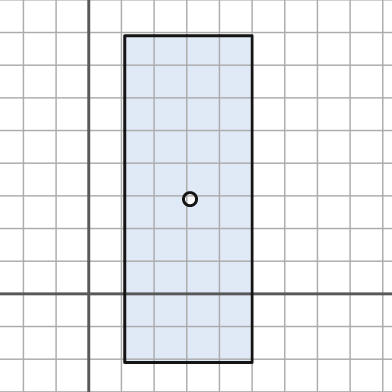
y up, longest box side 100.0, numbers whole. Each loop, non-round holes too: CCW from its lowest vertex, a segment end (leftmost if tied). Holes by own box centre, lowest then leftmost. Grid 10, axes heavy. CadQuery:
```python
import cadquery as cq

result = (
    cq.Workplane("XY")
    .moveTo(11.0, -21.0)
    .lineTo(50.0, -21.0)
    .lineTo(50.0, 79.0)
    .lineTo(11.0, 79.0)
    .close()
    .moveTo(31.0, 29.0)
    .circle(2.0)
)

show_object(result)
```